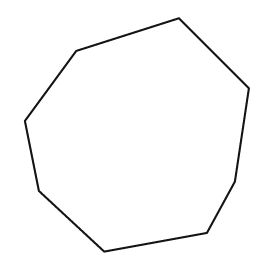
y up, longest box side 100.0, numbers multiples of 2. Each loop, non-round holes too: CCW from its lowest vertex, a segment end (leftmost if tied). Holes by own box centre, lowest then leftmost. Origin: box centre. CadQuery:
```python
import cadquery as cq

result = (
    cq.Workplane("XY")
    .moveTo(-14.0, -50.0)
    .lineTo(30.0, -42.0)
    .lineTo(42.0, -20.0)
    .lineTo(48.0, 20.0)
    .lineTo(18.0, 50.0)
    .lineTo(-26.0, 36.0)
    .lineTo(-48.0, 6.0)
    .lineTo(-42.0, -24.0)
    .close()
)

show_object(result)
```